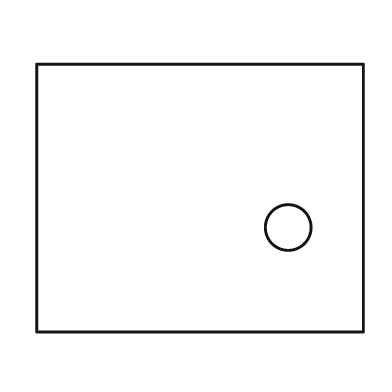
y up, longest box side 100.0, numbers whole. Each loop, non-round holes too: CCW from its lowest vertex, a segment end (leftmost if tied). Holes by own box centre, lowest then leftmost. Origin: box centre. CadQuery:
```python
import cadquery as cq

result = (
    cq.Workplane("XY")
    .moveTo(-50.0, -41.0)
    .lineTo(50.0, -41.0)
    .lineTo(50.0, 41.0)
    .lineTo(-50.0, 41.0)
    .close()
    .moveTo(27.0, -9.0)
    .circle(7.0)
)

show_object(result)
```